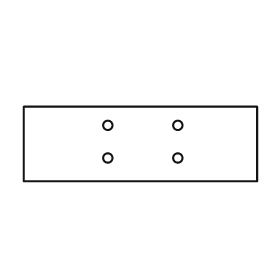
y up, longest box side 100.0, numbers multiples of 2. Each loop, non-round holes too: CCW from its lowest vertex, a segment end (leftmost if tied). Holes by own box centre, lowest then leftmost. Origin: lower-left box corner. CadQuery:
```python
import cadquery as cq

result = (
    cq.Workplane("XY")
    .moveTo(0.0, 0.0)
    .lineTo(100.0, 0.0)
    .lineTo(100.0, 32.0)
    .lineTo(0.0, 32.0)
    .close()
    .moveTo(36.0, 10.0)
    .circle(2.0)
    .moveTo(66.0, 10.0)
    .circle(2.0)
    .moveTo(36.0, 24.0)
    .circle(2.0)
    .moveTo(66.0, 24.0)
    .circle(2.0)
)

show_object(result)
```